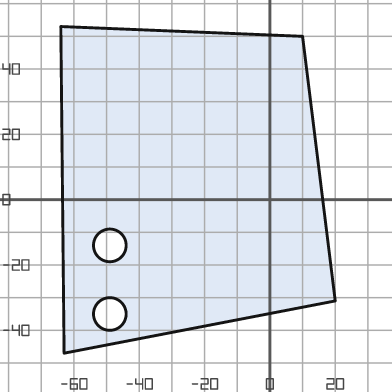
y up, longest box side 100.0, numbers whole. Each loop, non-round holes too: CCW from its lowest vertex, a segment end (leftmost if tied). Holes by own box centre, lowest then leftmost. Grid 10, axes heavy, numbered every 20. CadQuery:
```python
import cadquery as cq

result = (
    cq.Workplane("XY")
    .moveTo(-63.0, -47.0)
    .lineTo(20.0, -31.0)
    .lineTo(10.0, 50.0)
    .lineTo(-64.0, 53.0)
    .close()
    .moveTo(-49.0, -35.0)
    .circle(5.0)
    .moveTo(-49.0, -14.0)
    .circle(5.0)
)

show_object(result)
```